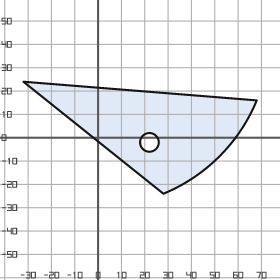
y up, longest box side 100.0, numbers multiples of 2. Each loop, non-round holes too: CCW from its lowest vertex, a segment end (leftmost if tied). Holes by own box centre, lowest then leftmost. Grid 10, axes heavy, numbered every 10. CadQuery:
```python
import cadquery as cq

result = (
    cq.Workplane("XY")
    .moveTo(28.0, -24.0)
    .threePointArc((52.0, -8.0), (68.0, 16.0))
    .lineTo(-32.0, 24.0)
    .close()
    .moveTo(22.0, -2.0)
    .circle(4.0)
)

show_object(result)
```